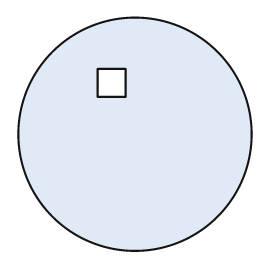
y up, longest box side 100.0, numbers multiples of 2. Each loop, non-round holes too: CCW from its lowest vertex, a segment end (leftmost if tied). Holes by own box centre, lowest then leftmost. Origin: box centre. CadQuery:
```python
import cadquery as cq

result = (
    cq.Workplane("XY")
    .moveTo(0.0, 0.0)
    .circle(50.0)
    .moveTo(-16.0, 16.0)
    .lineTo(-4.0, 16.0)
    .lineTo(-4.0, 28.0)
    .lineTo(-16.0, 28.0)
    .close()
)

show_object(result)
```